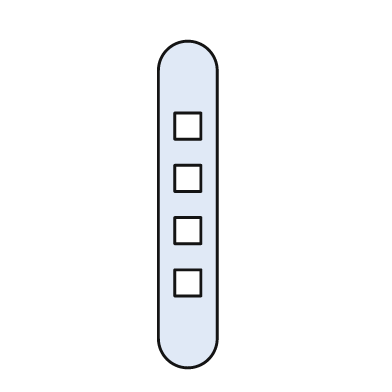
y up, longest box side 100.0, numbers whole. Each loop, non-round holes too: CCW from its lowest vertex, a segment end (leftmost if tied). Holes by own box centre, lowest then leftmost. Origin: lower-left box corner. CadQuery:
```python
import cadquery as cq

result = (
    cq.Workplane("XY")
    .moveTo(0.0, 9.0)
    .threePointArc((9.0, 0.0), (18.0, 9.0))
    .lineTo(18.0, 91.0)
    .threePointArc((9.0, 100.0), (0.0, 91.0))
    .close()
    .moveTo(5.0, 22.0)
    .lineTo(13.0, 22.0)
    .lineTo(13.0, 30.0)
    .lineTo(5.0, 30.0)
    .close()
    .moveTo(5.0, 38.0)
    .lineTo(13.0, 38.0)
    .lineTo(13.0, 46.0)
    .lineTo(5.0, 46.0)
    .close()
    .moveTo(5.0, 54.0)
    .lineTo(13.0, 54.0)
    .lineTo(13.0, 62.0)
    .lineTo(5.0, 62.0)
    .close()
    .moveTo(5.0, 70.0)
    .lineTo(13.0, 70.0)
    .lineTo(13.0, 78.0)
    .lineTo(5.0, 78.0)
    .close()
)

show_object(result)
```